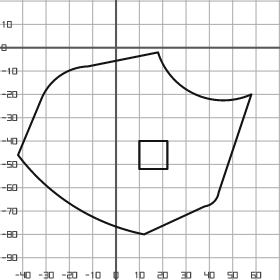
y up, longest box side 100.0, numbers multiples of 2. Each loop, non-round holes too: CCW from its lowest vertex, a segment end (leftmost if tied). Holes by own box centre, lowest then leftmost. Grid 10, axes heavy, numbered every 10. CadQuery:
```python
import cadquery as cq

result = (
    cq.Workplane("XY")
    .moveTo(12.0, -80.0)
    .lineTo(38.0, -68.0)
    .threePointArc((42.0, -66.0), (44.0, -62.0))
    .lineTo(58.0, -20.0)
    .threePointArc((34.0, -20.0), (18.0, -2.0))
    .lineTo(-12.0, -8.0)
    .threePointArc((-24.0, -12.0), (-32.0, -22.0))
    .lineTo(-42.0, -46.0)
    .threePointArc((-18.0, -68.0), (12.0, -80.0))
    .close()
    .moveTo(10.0, -52.0)
    .lineTo(22.0, -52.0)
    .lineTo(22.0, -40.0)
    .lineTo(10.0, -40.0)
    .close()
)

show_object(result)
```